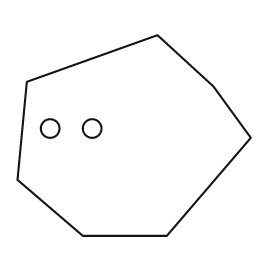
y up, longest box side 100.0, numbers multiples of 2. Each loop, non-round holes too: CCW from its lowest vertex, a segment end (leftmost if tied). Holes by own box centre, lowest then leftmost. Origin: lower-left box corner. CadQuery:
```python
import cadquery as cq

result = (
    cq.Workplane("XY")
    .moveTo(28.0, 0.0)
    .lineTo(64.0, 0.0)
    .lineTo(100.0, 42.0)
    .lineTo(84.0, 64.0)
    .lineTo(60.0, 86.0)
    .lineTo(4.0, 66.0)
    .lineTo(0.0, 24.0)
    .close()
    .moveTo(14.0, 46.0)
    .circle(4.0)
    .moveTo(32.0, 46.0)
    .circle(4.0)
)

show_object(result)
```